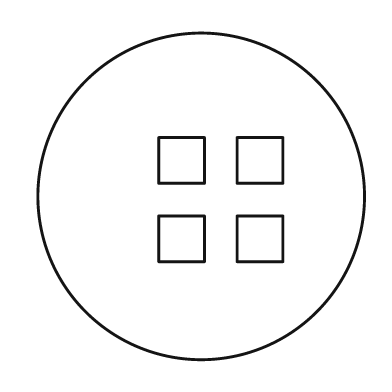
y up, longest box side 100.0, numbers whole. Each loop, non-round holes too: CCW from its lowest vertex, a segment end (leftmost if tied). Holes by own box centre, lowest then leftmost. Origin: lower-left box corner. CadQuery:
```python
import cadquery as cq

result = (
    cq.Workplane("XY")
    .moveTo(50.0, 50.0)
    .circle(50.0)
    .moveTo(37.0, 30.0)
    .lineTo(51.0, 30.0)
    .lineTo(51.0, 44.0)
    .lineTo(37.0, 44.0)
    .close()
    .moveTo(61.0, 30.0)
    .lineTo(75.0, 30.0)
    .lineTo(75.0, 44.0)
    .lineTo(61.0, 44.0)
    .close()
    .moveTo(37.0, 54.0)
    .lineTo(51.0, 54.0)
    .lineTo(51.0, 68.0)
    .lineTo(37.0, 68.0)
    .close()
    .moveTo(61.0, 54.0)
    .lineTo(75.0, 54.0)
    .lineTo(75.0, 68.0)
    .lineTo(61.0, 68.0)
    .close()
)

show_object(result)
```